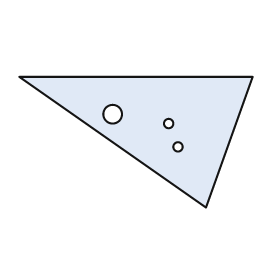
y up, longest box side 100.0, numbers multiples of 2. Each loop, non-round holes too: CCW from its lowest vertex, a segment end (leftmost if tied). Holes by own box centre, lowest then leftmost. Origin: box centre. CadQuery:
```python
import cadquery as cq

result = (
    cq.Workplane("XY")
    .moveTo(30.0, -28.0)
    .lineTo(50.0, 28.0)
    .lineTo(-50.0, 28.0)
    .close()
    .moveTo(18.0, -2.0)
    .circle(2.0)
    .moveTo(14.0, 8.0)
    .circle(2.0)
    .moveTo(-10.0, 12.0)
    .circle(4.0)
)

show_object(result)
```